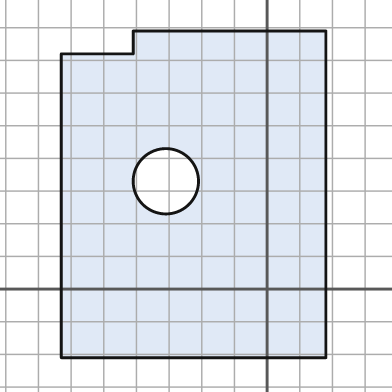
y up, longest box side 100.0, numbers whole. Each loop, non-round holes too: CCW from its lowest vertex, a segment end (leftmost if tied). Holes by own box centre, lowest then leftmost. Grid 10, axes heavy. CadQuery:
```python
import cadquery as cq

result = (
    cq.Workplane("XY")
    .moveTo(-63.0, -21.0)
    .lineTo(18.0, -21.0)
    .lineTo(18.0, 79.0)
    .lineTo(-41.0, 79.0)
    .lineTo(-41.0, 72.0)
    .lineTo(-63.0, 72.0)
    .close()
    .moveTo(-31.0, 33.0)
    .circle(10.0)
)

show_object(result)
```